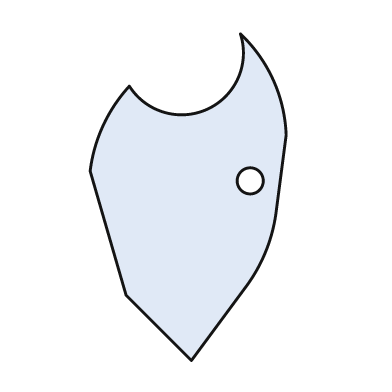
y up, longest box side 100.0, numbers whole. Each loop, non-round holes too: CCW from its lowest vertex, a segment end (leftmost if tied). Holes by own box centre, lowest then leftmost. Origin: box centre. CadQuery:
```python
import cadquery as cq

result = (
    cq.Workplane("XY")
    .moveTo(1.0, -50.0)
    .lineTo(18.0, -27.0)
    .threePointArc((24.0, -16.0), (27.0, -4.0))
    .lineTo(30.0, 19.0)
    .threePointArc((26.0, 36.0), (16.0, 50.0))
    .threePointArc((6.0, 27.0), (-18.0, 34.0))
    .threePointArc((-26.0, 22.0), (-30.0, 8.0))
    .lineTo(-19.0, -30.0)
    .close()
    .moveTo(19.0, 5.0)
    .circle(4.0)
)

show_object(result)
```